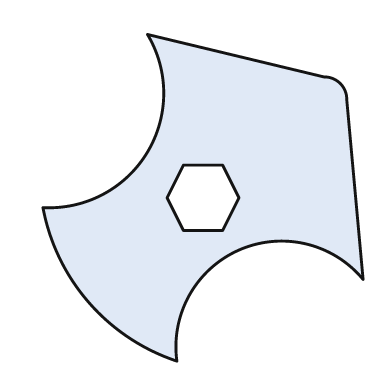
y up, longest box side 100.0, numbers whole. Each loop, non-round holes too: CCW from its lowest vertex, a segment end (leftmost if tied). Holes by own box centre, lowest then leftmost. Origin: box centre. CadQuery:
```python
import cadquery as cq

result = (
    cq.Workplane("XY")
    .moveTo(-8.0, -50.0)
    .threePointArc((11.0, -16.0), (49.0, -25.0))
    .lineTo(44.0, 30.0)
    .threePointArc((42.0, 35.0), (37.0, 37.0))
    .lineTo(-17.0, 50.0)
    .threePointArc((-17.0, 14.0), (-49.0, -3.0))
    .threePointArc((-35.0, -32.0), (-8.0, -50.0))
    .close()
    .moveTo(-6.0, -10.0)
    .lineTo(6.0, -10.0)
    .lineTo(11.0, 0.0)
    .lineTo(6.0, 10.0)
    .lineTo(-6.0, 10.0)
    .lineTo(-11.0, 0.0)
    .close()
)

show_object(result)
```